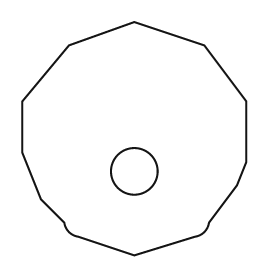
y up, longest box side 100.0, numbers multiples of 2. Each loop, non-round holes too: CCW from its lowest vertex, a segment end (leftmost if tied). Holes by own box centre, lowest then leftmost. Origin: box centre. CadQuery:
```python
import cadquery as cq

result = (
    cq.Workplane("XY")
    .moveTo(0.0, -50.0)
    .lineTo(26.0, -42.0)
    .threePointArc((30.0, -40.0), (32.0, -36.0))
    .lineTo(44.0, -20.0)
    .lineTo(48.0, -10.0)
    .lineTo(48.0, 16.0)
    .lineTo(30.0, 40.0)
    .lineTo(0.0, 50.0)
    .lineTo(-28.0, 40.0)
    .lineTo(-48.0, 16.0)
    .lineTo(-48.0, -6.0)
    .lineTo(-40.0, -26.0)
    .lineTo(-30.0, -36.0)
    .threePointArc((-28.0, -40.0), (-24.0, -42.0))
    .close()
    .moveTo(0.0, -14.0)
    .circle(10.0)
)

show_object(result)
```